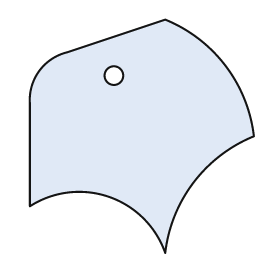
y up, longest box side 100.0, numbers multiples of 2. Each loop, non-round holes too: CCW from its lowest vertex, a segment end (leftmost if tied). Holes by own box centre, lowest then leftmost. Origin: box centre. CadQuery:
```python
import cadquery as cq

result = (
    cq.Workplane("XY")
    .moveTo(10.0, -50.0)
    .threePointArc((22.0, -20.0), (48.0, 0.0))
    .threePointArc((36.0, 30.0), (10.0, 50.0))
    .lineTo(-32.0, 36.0)
    .threePointArc((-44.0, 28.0), (-48.0, 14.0))
    .lineTo(-48.0, -30.0)
    .threePointArc((-14.0, -26.0), (10.0, -50.0))
    .close()
    .moveTo(-12.0, 26.0)
    .circle(4.0)
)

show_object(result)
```